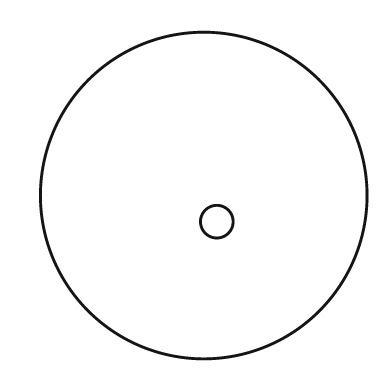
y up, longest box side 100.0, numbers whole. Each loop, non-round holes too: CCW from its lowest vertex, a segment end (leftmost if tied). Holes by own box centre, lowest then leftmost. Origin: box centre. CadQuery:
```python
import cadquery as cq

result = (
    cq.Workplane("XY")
    .moveTo(0.0, 0.0)
    .circle(50.0)
    .moveTo(4.0, -8.0)
    .circle(5.0)
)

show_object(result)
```